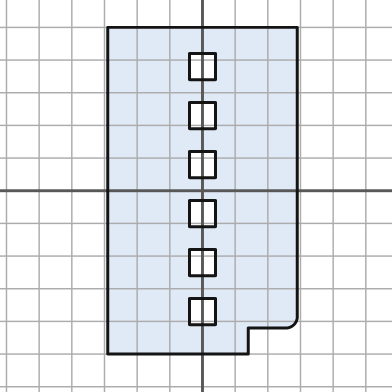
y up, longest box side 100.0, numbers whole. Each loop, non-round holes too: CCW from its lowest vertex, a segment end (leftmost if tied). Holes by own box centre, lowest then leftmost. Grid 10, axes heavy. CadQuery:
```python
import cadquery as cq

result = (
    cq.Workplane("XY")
    .moveTo(-29.0, -50.0)
    .lineTo(14.0, -50.0)
    .lineTo(14.0, -42.0)
    .lineTo(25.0, -42.0)
    .threePointArc((28.0, -41.0), (29.0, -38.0))
    .lineTo(29.0, 50.0)
    .lineTo(-29.0, 50.0)
    .close()
    .moveTo(-4.0, -41.0)
    .lineTo(4.0, -41.0)
    .lineTo(4.0, -33.0)
    .lineTo(-4.0, -33.0)
    .close()
    .moveTo(-4.0, -26.0)
    .lineTo(4.0, -26.0)
    .lineTo(4.0, -18.0)
    .lineTo(-4.0, -18.0)
    .close()
    .moveTo(-4.0, -11.0)
    .lineTo(4.0, -11.0)
    .lineTo(4.0, -3.0)
    .lineTo(-4.0, -3.0)
    .close()
    .moveTo(-4.0, 4.0)
    .lineTo(4.0, 4.0)
    .lineTo(4.0, 12.0)
    .lineTo(-4.0, 12.0)
    .close()
    .moveTo(-4.0, 19.0)
    .lineTo(4.0, 19.0)
    .lineTo(4.0, 27.0)
    .lineTo(-4.0, 27.0)
    .close()
    .moveTo(-4.0, 34.0)
    .lineTo(4.0, 34.0)
    .lineTo(4.0, 42.0)
    .lineTo(-4.0, 42.0)
    .close()
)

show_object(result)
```